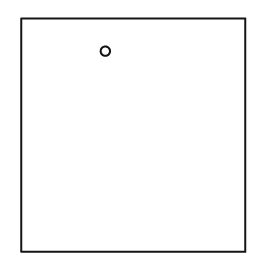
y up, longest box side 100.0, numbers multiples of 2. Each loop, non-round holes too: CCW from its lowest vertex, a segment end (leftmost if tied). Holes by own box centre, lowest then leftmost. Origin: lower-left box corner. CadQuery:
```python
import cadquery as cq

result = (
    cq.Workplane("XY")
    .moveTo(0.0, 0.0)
    .lineTo(96.0, 0.0)
    .lineTo(96.0, 100.0)
    .lineTo(0.0, 100.0)
    .close()
    .moveTo(36.0, 86.0)
    .circle(2.0)
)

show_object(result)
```